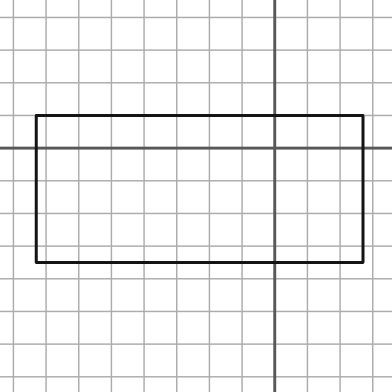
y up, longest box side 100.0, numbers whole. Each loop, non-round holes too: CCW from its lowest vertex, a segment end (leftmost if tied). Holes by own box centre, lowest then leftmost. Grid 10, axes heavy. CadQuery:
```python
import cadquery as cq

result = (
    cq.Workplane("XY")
    .moveTo(-73.0, -35.0)
    .lineTo(27.0, -35.0)
    .lineTo(27.0, 10.0)
    .lineTo(-73.0, 10.0)
    .close()
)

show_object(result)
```